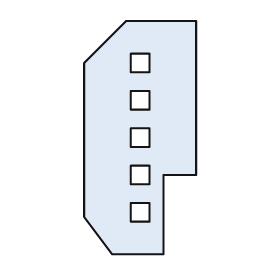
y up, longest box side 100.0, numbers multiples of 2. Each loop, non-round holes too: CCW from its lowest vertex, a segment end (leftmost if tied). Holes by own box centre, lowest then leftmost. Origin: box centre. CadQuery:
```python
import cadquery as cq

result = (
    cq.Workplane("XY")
    .moveTo(-12.0, -50.0)
    .lineTo(10.0, -50.0)
    .lineTo(10.0, -16.0)
    .lineTo(24.0, -16.0)
    .lineTo(24.0, 50.0)
    .lineTo(-6.0, 50.0)
    .lineTo(-24.0, 32.0)
    .lineTo(-24.0, -34.0)
    .close()
    .moveTo(-4.0, -36.0)
    .lineTo(4.0, -36.0)
    .lineTo(4.0, -28.0)
    .lineTo(-4.0, -28.0)
    .close()
    .moveTo(-4.0, -20.0)
    .lineTo(4.0, -20.0)
    .lineTo(4.0, -12.0)
    .lineTo(-4.0, -12.0)
    .close()
    .moveTo(-4.0, -4.0)
    .lineTo(4.0, -4.0)
    .lineTo(4.0, 4.0)
    .lineTo(-4.0, 4.0)
    .close()
    .moveTo(-4.0, 12.0)
    .lineTo(4.0, 12.0)
    .lineTo(4.0, 20.0)
    .lineTo(-4.0, 20.0)
    .close()
    .moveTo(-4.0, 28.0)
    .lineTo(4.0, 28.0)
    .lineTo(4.0, 36.0)
    .lineTo(-4.0, 36.0)
    .close()
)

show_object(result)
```